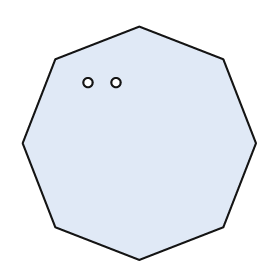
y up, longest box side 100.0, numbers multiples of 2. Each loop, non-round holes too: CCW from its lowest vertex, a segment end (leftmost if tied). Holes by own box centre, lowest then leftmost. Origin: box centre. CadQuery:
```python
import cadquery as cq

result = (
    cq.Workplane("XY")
    .moveTo(0.0, -50.0)
    .lineTo(36.0, -36.0)
    .lineTo(50.0, 0.0)
    .lineTo(36.0, 36.0)
    .lineTo(0.0, 50.0)
    .lineTo(-36.0, 36.0)
    .lineTo(-50.0, 0.0)
    .lineTo(-36.0, -36.0)
    .close()
    .moveTo(-22.0, 26.0)
    .circle(2.0)
    .moveTo(-10.0, 26.0)
    .circle(2.0)
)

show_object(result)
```